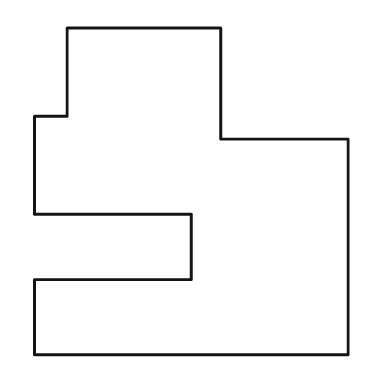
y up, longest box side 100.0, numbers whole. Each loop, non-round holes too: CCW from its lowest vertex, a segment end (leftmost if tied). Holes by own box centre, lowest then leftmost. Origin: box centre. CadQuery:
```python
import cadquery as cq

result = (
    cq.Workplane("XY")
    .moveTo(-48.0, -50.0)
    .lineTo(48.0, -50.0)
    .lineTo(48.0, 16.0)
    .lineTo(9.0, 16.0)
    .lineTo(9.0, 50.0)
    .lineTo(-38.0, 50.0)
    .lineTo(-38.0, 23.0)
    .lineTo(-48.0, 23.0)
    .lineTo(-48.0, -7.0)
    .lineTo(0.0, -7.0)
    .lineTo(0.0, -27.0)
    .lineTo(-48.0, -27.0)
    .close()
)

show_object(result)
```